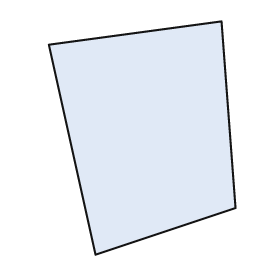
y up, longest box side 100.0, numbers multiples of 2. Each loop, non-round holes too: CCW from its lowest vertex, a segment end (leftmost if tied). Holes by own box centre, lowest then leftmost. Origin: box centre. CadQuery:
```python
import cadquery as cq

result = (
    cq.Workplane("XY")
    .moveTo(-20.0, -50.0)
    .lineTo(40.0, -30.0)
    .lineTo(34.0, 50.0)
    .lineTo(-40.0, 40.0)
    .close()
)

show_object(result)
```